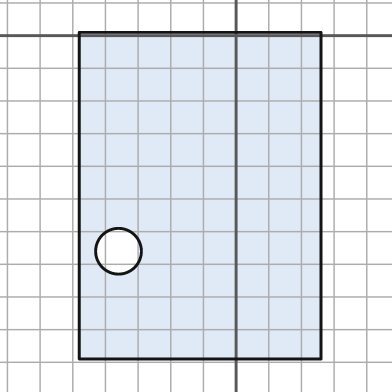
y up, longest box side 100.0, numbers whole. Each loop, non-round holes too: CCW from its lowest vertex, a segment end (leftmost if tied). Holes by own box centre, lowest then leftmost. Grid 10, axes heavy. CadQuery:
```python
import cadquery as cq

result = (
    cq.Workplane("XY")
    .moveTo(-48.0, -99.0)
    .lineTo(26.0, -99.0)
    .lineTo(26.0, 1.0)
    .lineTo(-48.0, 1.0)
    .close()
    .moveTo(-36.0, -66.0)
    .circle(7.0)
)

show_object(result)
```